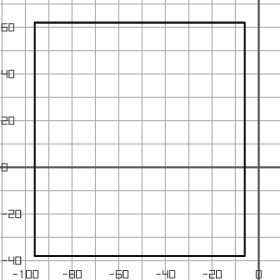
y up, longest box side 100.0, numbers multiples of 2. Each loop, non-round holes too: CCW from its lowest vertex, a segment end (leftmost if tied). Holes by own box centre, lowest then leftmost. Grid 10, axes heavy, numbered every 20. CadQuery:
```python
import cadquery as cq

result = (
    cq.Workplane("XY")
    .moveTo(-96.0, -38.0)
    .lineTo(-6.0, -38.0)
    .lineTo(-6.0, 62.0)
    .lineTo(-96.0, 62.0)
    .close()
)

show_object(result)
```